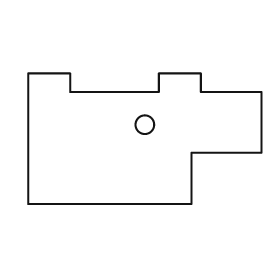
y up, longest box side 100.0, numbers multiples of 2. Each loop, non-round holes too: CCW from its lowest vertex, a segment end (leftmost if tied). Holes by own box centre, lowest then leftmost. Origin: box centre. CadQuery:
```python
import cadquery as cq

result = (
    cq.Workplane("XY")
    .moveTo(-50.0, -28.0)
    .lineTo(20.0, -28.0)
    .lineTo(20.0, -6.0)
    .lineTo(50.0, -6.0)
    .lineTo(50.0, 20.0)
    .lineTo(24.0, 20.0)
    .lineTo(24.0, 28.0)
    .lineTo(6.0, 28.0)
    .lineTo(6.0, 20.0)
    .lineTo(-32.0, 20.0)
    .lineTo(-32.0, 28.0)
    .lineTo(-50.0, 28.0)
    .close()
    .moveTo(0.0, 6.0)
    .circle(4.0)
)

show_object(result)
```